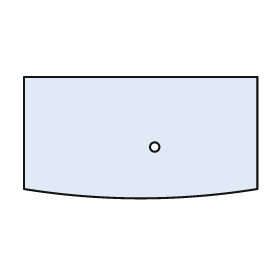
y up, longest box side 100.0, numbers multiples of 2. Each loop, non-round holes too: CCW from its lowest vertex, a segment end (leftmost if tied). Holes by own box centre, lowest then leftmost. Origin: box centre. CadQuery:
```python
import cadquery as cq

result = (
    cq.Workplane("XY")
    .moveTo(-50.0, -22.0)
    .threePointArc((0.0, -26.0), (50.0, -22.0))
    .lineTo(50.0, 26.0)
    .lineTo(-50.0, 26.0)
    .close()
    .moveTo(6.0, -4.0)
    .circle(2.0)
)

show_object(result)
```